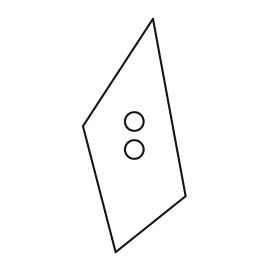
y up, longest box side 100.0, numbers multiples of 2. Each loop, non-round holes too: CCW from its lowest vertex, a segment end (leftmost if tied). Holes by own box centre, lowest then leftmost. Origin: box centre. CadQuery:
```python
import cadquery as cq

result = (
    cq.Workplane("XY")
    .moveTo(-8.0, -50.0)
    .lineTo(22.0, -26.0)
    .lineTo(8.0, 50.0)
    .lineTo(-22.0, 4.0)
    .close()
    .moveTo(0.0, -6.0)
    .circle(4.0)
    .moveTo(0.0, 6.0)
    .circle(4.0)
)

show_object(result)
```